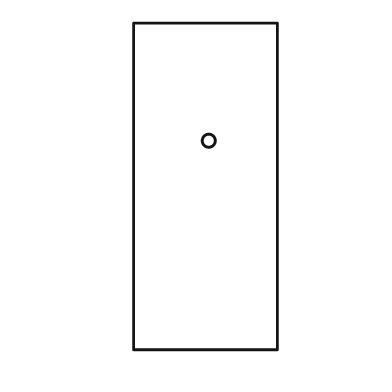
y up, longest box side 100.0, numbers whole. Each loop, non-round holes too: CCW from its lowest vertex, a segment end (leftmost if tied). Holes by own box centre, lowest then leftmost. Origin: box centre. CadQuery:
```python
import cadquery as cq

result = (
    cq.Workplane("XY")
    .moveTo(-22.0, -50.0)
    .lineTo(22.0, -50.0)
    .lineTo(22.0, 50.0)
    .lineTo(-22.0, 50.0)
    .close()
    .moveTo(1.0, 14.0)
    .circle(2.0)
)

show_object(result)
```